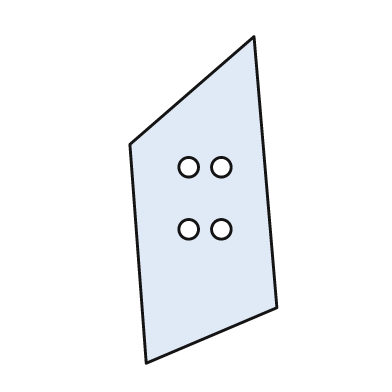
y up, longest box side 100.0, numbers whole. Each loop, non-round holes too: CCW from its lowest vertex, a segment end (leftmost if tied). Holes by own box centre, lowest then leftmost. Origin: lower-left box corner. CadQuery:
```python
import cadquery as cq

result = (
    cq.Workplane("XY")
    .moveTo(5.0, 0.0)
    .lineTo(45.0, 17.0)
    .lineTo(38.0, 100.0)
    .lineTo(0.0, 67.0)
    .close()
    .moveTo(18.0, 41.0)
    .circle(3.0)
    .moveTo(28.0, 41.0)
    .circle(3.0)
    .moveTo(18.0, 60.0)
    .circle(3.0)
    .moveTo(28.0, 60.0)
    .circle(3.0)
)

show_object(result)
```